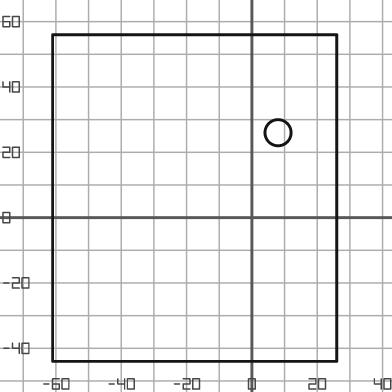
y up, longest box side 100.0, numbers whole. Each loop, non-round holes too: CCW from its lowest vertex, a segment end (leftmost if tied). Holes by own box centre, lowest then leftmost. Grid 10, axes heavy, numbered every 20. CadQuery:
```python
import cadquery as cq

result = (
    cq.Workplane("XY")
    .moveTo(-61.0, -44.0)
    .lineTo(26.0, -44.0)
    .lineTo(26.0, 56.0)
    .lineTo(-61.0, 56.0)
    .close()
    .moveTo(8.0, 26.0)
    .circle(4.0)
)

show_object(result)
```